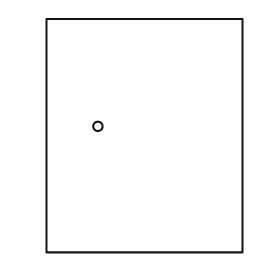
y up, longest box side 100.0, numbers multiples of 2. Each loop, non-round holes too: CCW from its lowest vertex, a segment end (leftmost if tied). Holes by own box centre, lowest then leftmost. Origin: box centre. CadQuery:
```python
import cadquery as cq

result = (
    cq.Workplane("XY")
    .moveTo(-42.0, -50.0)
    .lineTo(42.0, -50.0)
    .lineTo(42.0, 50.0)
    .lineTo(-42.0, 50.0)
    .close()
    .moveTo(-20.0, 4.0)
    .circle(2.0)
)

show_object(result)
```